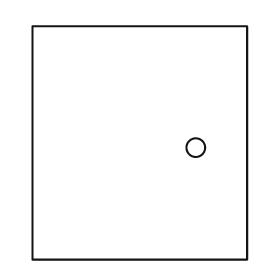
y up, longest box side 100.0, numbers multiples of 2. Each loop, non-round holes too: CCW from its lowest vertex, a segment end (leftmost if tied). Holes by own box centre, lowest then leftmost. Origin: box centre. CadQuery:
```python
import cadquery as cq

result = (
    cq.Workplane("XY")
    .moveTo(-46.0, -50.0)
    .lineTo(46.0, -50.0)
    .lineTo(46.0, 50.0)
    .lineTo(-46.0, 50.0)
    .close()
    .moveTo(24.0, -2.0)
    .circle(4.0)
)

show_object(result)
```